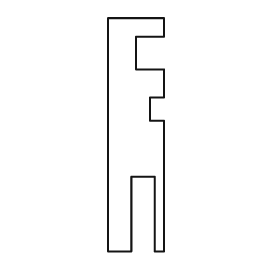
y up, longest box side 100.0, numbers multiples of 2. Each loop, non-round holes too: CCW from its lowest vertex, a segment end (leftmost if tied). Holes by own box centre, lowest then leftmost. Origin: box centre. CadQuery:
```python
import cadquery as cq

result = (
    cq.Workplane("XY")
    .moveTo(-12.0, -50.0)
    .lineTo(-2.0, -50.0)
    .lineTo(-2.0, -18.0)
    .lineTo(8.0, -18.0)
    .lineTo(8.0, -50.0)
    .lineTo(12.0, -50.0)
    .lineTo(12.0, 6.0)
    .lineTo(6.0, 6.0)
    .lineTo(6.0, 16.0)
    .lineTo(12.0, 16.0)
    .lineTo(12.0, 28.0)
    .lineTo(0.0, 28.0)
    .lineTo(0.0, 42.0)
    .lineTo(12.0, 42.0)
    .lineTo(12.0, 50.0)
    .lineTo(-12.0, 50.0)
    .close()
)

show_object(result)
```